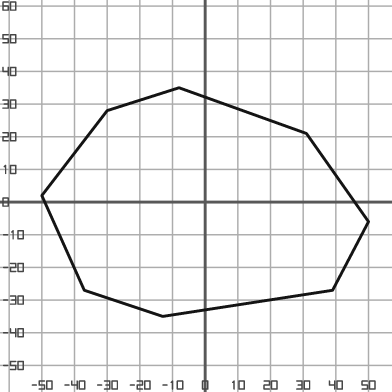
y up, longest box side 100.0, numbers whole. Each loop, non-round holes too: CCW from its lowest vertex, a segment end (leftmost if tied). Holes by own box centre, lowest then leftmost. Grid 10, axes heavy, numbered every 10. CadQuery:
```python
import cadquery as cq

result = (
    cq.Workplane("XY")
    .moveTo(-13.0, -35.0)
    .lineTo(39.0, -27.0)
    .lineTo(50.0, -6.0)
    .lineTo(31.0, 21.0)
    .lineTo(-8.0, 35.0)
    .lineTo(-30.0, 28.0)
    .lineTo(-50.0, 2.0)
    .lineTo(-37.0, -27.0)
    .close()
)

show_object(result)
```